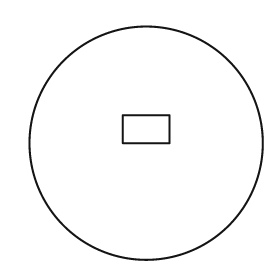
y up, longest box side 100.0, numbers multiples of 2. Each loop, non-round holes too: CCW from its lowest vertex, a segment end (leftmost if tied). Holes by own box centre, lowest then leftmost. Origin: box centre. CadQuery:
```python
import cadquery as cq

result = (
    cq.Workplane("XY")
    .moveTo(0.0, 0.0)
    .circle(50.0)
    .moveTo(-10.0, 0.0)
    .lineTo(10.0, 0.0)
    .lineTo(10.0, 12.0)
    .lineTo(-10.0, 12.0)
    .close()
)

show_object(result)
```